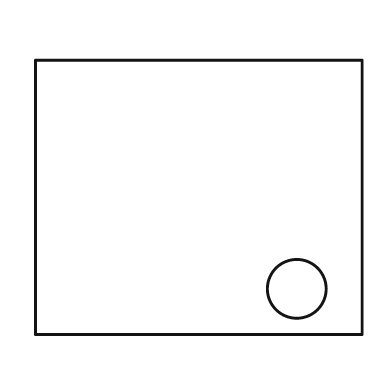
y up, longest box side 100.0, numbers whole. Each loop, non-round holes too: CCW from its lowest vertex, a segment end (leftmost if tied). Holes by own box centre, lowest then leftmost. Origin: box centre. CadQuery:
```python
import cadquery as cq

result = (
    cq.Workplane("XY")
    .moveTo(-50.0, -42.0)
    .lineTo(50.0, -42.0)
    .lineTo(50.0, 42.0)
    .lineTo(-50.0, 42.0)
    .close()
    .moveTo(30.0, -28.0)
    .circle(9.0)
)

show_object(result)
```